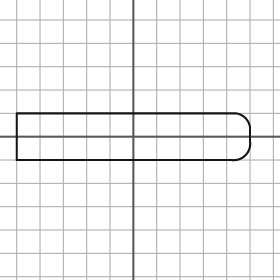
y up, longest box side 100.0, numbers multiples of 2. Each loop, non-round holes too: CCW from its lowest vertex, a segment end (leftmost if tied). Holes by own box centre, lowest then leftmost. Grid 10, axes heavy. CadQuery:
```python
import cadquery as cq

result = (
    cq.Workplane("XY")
    .moveTo(-50.0, -10.0)
    .lineTo(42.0, -10.0)
    .threePointArc((48.0, -8.0), (50.0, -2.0))
    .lineTo(50.0, 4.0)
    .threePointArc((48.0, 8.0), (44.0, 10.0))
    .lineTo(-50.0, 10.0)
    .close()
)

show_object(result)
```